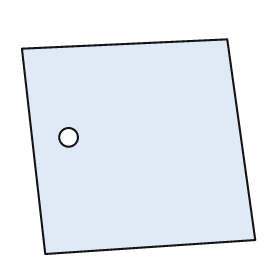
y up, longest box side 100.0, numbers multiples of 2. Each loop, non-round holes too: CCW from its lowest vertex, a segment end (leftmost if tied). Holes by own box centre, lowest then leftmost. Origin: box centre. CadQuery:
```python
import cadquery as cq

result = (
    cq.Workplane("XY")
    .moveTo(-40.0, -46.0)
    .lineTo(50.0, -40.0)
    .lineTo(38.0, 46.0)
    .lineTo(-50.0, 42.0)
    .close()
    .moveTo(-30.0, 4.0)
    .circle(4.0)
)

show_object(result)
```